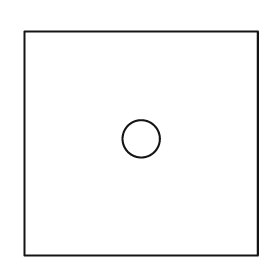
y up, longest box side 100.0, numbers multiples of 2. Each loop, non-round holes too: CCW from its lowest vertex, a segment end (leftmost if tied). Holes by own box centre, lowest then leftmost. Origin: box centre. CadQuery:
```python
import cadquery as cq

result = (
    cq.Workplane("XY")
    .moveTo(-50.0, -48.0)
    .lineTo(50.0, -48.0)
    .lineTo(50.0, 48.0)
    .lineTo(-50.0, 48.0)
    .close()
    .moveTo(0.0, 2.0)
    .circle(8.0)
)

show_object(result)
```